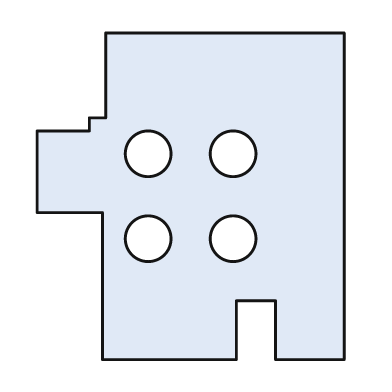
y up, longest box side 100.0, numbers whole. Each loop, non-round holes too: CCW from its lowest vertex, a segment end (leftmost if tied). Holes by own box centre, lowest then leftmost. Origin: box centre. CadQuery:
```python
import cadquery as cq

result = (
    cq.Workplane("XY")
    .moveTo(-27.0, -50.0)
    .lineTo(14.0, -50.0)
    .lineTo(14.0, -32.0)
    .lineTo(26.0, -32.0)
    .lineTo(26.0, -50.0)
    .lineTo(47.0, -50.0)
    .lineTo(47.0, 50.0)
    .lineTo(-26.0, 50.0)
    .lineTo(-26.0, 24.0)
    .lineTo(-31.0, 24.0)
    .lineTo(-31.0, 20.0)
    .lineTo(-47.0, 20.0)
    .lineTo(-47.0, -5.0)
    .lineTo(-27.0, -5.0)
    .close()
    .moveTo(-13.0, -13.0)
    .circle(7.0)
    .moveTo(13.0, -13.0)
    .circle(7.0)
    .moveTo(-13.0, 13.0)
    .circle(7.0)
    .moveTo(13.0, 13.0)
    .circle(7.0)
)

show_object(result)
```